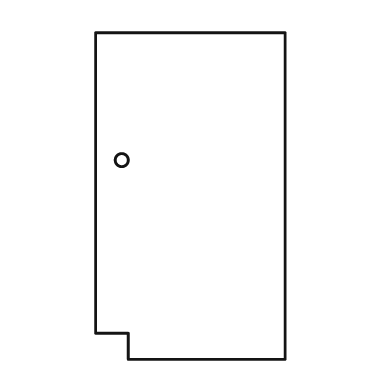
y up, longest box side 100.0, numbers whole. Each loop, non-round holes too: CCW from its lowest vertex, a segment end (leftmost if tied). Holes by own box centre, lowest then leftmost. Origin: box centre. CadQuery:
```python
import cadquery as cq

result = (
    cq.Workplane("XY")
    .moveTo(-19.0, -50.0)
    .lineTo(29.0, -50.0)
    .lineTo(29.0, 50.0)
    .lineTo(-29.0, 50.0)
    .lineTo(-29.0, -42.0)
    .lineTo(-19.0, -42.0)
    .close()
    .moveTo(-21.0, 11.0)
    .circle(2.0)
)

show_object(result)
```